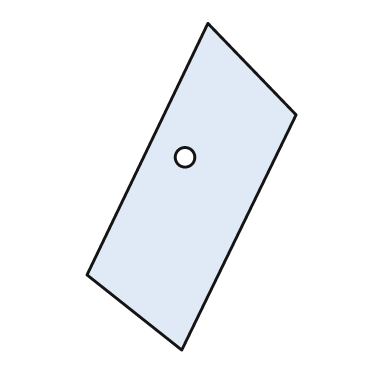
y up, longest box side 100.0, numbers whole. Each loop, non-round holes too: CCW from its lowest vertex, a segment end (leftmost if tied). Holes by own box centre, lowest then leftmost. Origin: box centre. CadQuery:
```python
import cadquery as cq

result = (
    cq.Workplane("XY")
    .moveTo(-3.0, -50.0)
    .lineTo(32.0, 22.0)
    .lineTo(5.0, 50.0)
    .lineTo(-32.0, -27.0)
    .close()
    .moveTo(-2.0, 9.0)
    .circle(3.0)
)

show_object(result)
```